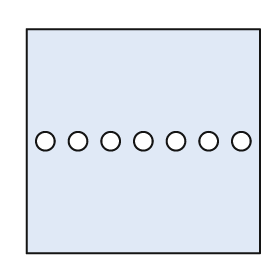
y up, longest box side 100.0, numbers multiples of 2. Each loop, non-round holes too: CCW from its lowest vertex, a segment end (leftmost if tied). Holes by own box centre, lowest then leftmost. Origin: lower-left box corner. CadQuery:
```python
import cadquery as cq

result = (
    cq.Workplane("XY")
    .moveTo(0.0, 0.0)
    .lineTo(100.0, 0.0)
    .lineTo(100.0, 96.0)
    .lineTo(0.0, 96.0)
    .close()
    .moveTo(8.0, 48.0)
    .circle(4.0)
    .moveTo(22.0, 48.0)
    .circle(4.0)
    .moveTo(36.0, 48.0)
    .circle(4.0)
    .moveTo(50.0, 48.0)
    .circle(4.0)
    .moveTo(64.0, 48.0)
    .circle(4.0)
    .moveTo(78.0, 48.0)
    .circle(4.0)
    .moveTo(92.0, 48.0)
    .circle(4.0)
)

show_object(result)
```